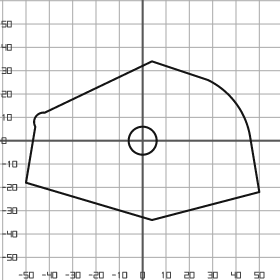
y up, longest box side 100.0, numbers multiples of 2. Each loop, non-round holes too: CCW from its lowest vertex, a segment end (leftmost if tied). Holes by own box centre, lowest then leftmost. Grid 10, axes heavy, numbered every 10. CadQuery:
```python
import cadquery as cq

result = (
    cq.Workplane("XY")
    .moveTo(4.0, -34.0)
    .lineTo(50.0, -22.0)
    .lineTo(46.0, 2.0)
    .threePointArc((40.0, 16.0), (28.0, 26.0))
    .lineTo(4.0, 34.0)
    .lineTo(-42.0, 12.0)
    .threePointArc((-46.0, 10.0), (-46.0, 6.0))
    .lineTo(-50.0, -18.0)
    .close()
    .moveTo(0.0, 0.0)
    .circle(6.0)
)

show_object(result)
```